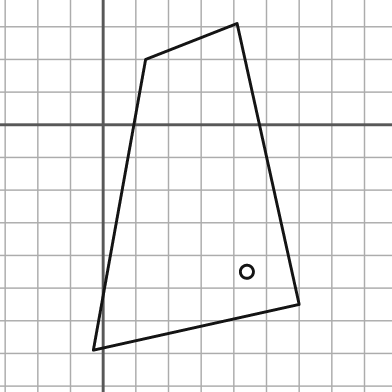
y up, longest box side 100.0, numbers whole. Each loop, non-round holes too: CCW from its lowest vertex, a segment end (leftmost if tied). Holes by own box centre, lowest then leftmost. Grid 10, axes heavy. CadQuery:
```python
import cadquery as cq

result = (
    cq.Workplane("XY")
    .moveTo(-3.0, -69.0)
    .lineTo(60.0, -55.0)
    .lineTo(41.0, 31.0)
    .lineTo(13.0, 20.0)
    .close()
    .moveTo(44.0, -45.0)
    .circle(2.0)
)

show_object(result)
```